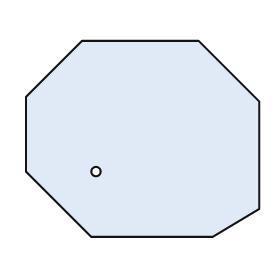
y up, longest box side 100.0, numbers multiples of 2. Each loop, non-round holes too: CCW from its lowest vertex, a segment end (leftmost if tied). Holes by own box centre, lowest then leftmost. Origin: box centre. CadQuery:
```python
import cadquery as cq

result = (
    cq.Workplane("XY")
    .moveTo(-22.0, -42.0)
    .lineTo(30.0, -42.0)
    .lineTo(50.0, -30.0)
    .lineTo(50.0, 16.0)
    .lineTo(24.0, 42.0)
    .lineTo(-26.0, 42.0)
    .lineTo(-50.0, 18.0)
    .lineTo(-50.0, -14.0)
    .close()
    .moveTo(-20.0, -14.0)
    .circle(2.0)
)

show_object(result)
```